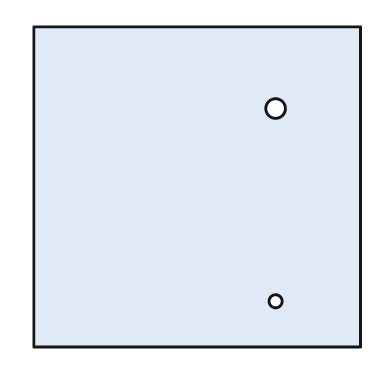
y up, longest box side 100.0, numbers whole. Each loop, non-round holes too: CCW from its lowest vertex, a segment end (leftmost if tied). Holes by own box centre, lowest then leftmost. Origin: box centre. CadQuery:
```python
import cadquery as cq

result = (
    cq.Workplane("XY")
    .moveTo(-50.0, -49.0)
    .lineTo(50.0, -49.0)
    .lineTo(50.0, 49.0)
    .lineTo(-50.0, 49.0)
    .close()
    .moveTo(24.0, -35.0)
    .circle(2.0)
    .moveTo(24.0, 24.0)
    .circle(3.0)
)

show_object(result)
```